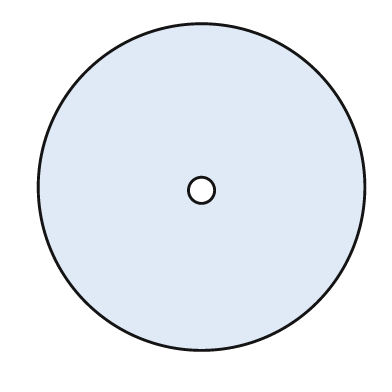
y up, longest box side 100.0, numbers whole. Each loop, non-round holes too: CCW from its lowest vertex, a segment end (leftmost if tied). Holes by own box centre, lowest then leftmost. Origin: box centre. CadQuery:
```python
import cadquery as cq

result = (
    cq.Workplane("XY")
    .moveTo(0.0, 0.0)
    .circle(50.0)
    .moveTo(0.0, -1.0)
    .circle(4.0)
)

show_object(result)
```